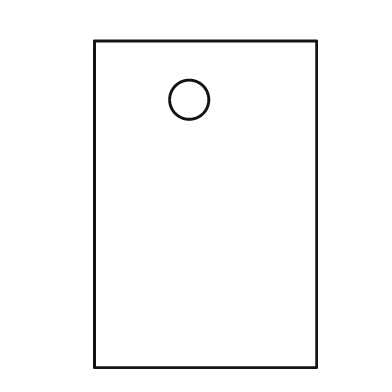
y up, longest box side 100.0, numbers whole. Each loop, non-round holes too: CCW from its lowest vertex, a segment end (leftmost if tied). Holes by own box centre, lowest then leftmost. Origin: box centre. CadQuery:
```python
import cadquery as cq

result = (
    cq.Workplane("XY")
    .moveTo(-34.0, -50.0)
    .lineTo(34.0, -50.0)
    .lineTo(34.0, 50.0)
    .lineTo(-34.0, 50.0)
    .close()
    .moveTo(-5.0, 32.0)
    .circle(6.0)
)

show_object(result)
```